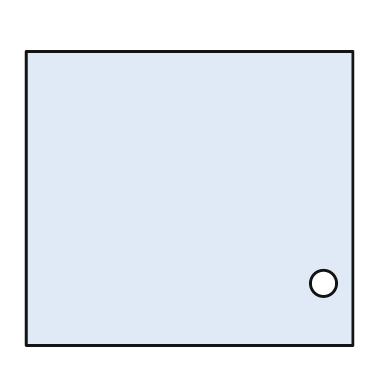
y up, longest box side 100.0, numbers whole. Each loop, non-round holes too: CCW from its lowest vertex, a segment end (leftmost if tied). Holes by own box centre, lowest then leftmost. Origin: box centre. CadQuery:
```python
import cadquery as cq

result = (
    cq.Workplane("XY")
    .moveTo(-50.0, -45.0)
    .lineTo(50.0, -45.0)
    .lineTo(50.0, 45.0)
    .lineTo(-50.0, 45.0)
    .close()
    .moveTo(41.0, -26.0)
    .circle(4.0)
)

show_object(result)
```